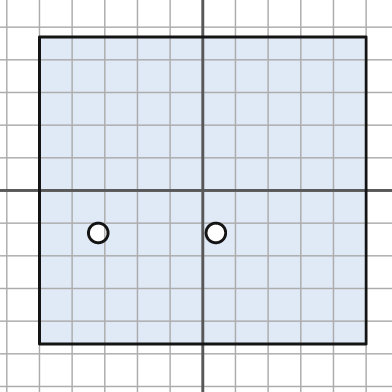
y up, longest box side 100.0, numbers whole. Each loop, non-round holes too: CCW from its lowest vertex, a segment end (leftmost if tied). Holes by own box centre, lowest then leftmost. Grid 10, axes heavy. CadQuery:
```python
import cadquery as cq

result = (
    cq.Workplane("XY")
    .moveTo(-50.0, -47.0)
    .lineTo(50.0, -47.0)
    .lineTo(50.0, 47.0)
    .lineTo(-50.0, 47.0)
    .close()
    .moveTo(-32.0, -13.0)
    .circle(3.0)
    .moveTo(4.0, -13.0)
    .circle(3.0)
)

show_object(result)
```